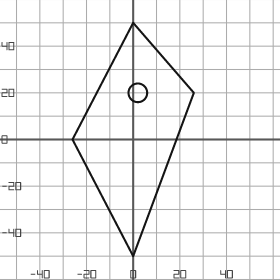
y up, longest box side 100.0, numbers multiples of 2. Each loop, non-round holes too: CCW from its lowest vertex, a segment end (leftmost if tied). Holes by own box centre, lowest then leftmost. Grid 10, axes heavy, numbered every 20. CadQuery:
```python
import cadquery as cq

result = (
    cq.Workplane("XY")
    .moveTo(0.0, -50.0)
    .lineTo(26.0, 20.0)
    .lineTo(0.0, 50.0)
    .lineTo(-26.0, 0.0)
    .close()
    .moveTo(2.0, 20.0)
    .circle(4.0)
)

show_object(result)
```